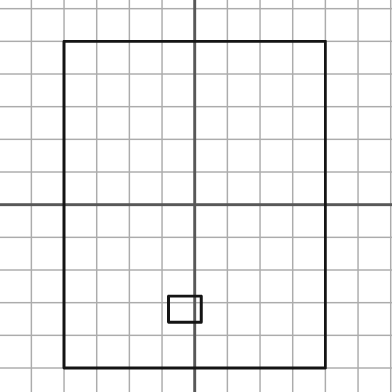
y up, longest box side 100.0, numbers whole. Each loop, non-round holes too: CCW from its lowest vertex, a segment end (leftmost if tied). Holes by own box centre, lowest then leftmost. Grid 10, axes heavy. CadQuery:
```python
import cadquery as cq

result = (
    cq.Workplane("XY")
    .moveTo(-40.0, -50.0)
    .lineTo(40.0, -50.0)
    .lineTo(40.0, 50.0)
    .lineTo(-40.0, 50.0)
    .close()
    .moveTo(-8.0, -36.0)
    .lineTo(2.0, -36.0)
    .lineTo(2.0, -28.0)
    .lineTo(-8.0, -28.0)
    .close()
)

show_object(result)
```